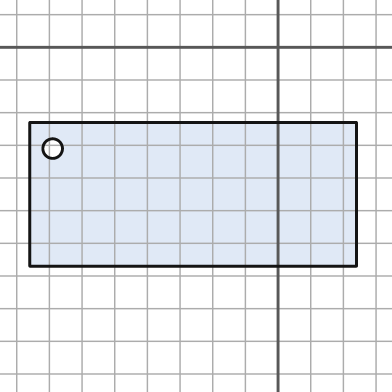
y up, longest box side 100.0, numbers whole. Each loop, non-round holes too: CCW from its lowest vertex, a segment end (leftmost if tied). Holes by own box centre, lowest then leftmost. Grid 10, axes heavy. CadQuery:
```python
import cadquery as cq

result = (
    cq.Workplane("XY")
    .moveTo(-76.0, -67.0)
    .lineTo(24.0, -67.0)
    .lineTo(24.0, -23.0)
    .lineTo(-76.0, -23.0)
    .close()
    .moveTo(-69.0, -31.0)
    .circle(3.0)
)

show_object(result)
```